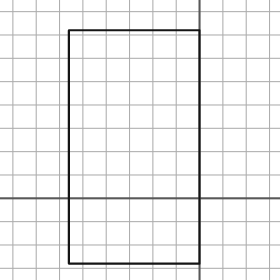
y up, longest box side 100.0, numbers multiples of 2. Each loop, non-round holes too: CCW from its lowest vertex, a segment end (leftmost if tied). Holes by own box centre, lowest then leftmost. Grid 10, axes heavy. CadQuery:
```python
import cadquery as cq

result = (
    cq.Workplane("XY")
    .moveTo(-56.0, -28.0)
    .lineTo(0.0, -28.0)
    .lineTo(0.0, 72.0)
    .lineTo(-56.0, 72.0)
    .close()
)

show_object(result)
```